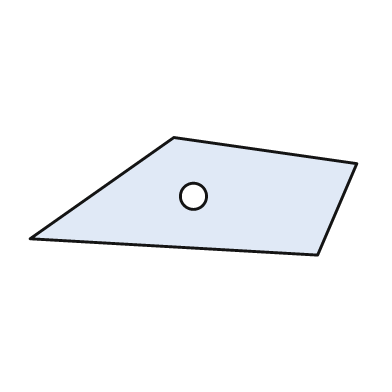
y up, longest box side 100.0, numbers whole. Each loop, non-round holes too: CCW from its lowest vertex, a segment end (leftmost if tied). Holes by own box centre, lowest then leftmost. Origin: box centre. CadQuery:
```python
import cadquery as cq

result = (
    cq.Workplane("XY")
    .moveTo(38.0, -18.0)
    .lineTo(50.0, 10.0)
    .lineTo(-6.0, 18.0)
    .lineTo(-50.0, -13.0)
    .close()
    .moveTo(0.0, 0.0)
    .circle(4.0)
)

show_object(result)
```